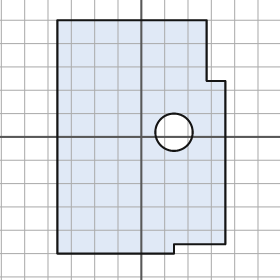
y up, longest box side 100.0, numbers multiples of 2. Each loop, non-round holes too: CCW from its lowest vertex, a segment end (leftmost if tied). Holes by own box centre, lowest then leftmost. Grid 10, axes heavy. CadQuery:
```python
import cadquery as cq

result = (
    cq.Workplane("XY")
    .moveTo(-36.0, -50.0)
    .lineTo(14.0, -50.0)
    .lineTo(14.0, -46.0)
    .lineTo(36.0, -46.0)
    .lineTo(36.0, 24.0)
    .lineTo(28.0, 24.0)
    .lineTo(28.0, 50.0)
    .lineTo(-36.0, 50.0)
    .close()
    .moveTo(14.0, 2.0)
    .circle(8.0)
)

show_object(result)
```